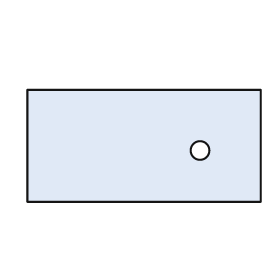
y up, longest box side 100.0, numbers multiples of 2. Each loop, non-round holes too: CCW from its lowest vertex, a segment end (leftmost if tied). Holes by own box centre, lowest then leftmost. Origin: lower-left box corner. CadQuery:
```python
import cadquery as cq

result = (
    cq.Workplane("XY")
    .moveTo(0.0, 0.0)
    .lineTo(100.0, 0.0)
    .lineTo(100.0, 48.0)
    .lineTo(0.0, 48.0)
    .close()
    .moveTo(74.0, 22.0)
    .circle(4.0)
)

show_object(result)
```